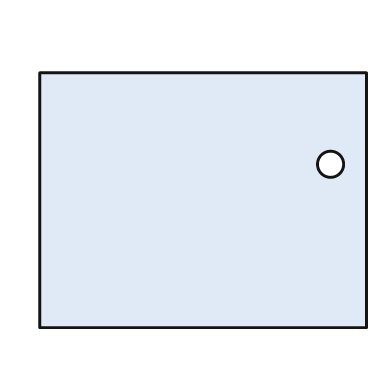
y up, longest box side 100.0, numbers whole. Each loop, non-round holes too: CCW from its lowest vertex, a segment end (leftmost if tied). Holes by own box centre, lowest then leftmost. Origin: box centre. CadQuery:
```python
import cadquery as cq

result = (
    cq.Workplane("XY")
    .moveTo(-50.0, -39.0)
    .lineTo(50.0, -39.0)
    .lineTo(50.0, 39.0)
    .lineTo(-50.0, 39.0)
    .close()
    .moveTo(39.0, 11.0)
    .circle(4.0)
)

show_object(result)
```